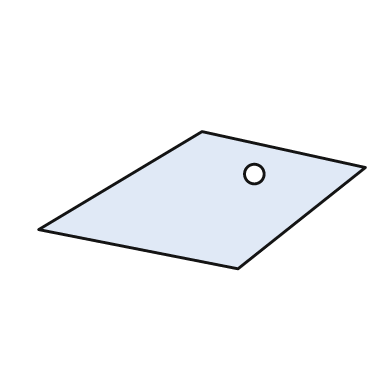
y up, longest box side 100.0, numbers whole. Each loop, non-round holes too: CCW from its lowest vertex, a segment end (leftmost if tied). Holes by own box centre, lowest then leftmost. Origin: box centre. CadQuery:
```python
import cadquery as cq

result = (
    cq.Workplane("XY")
    .moveTo(11.0, -21.0)
    .lineTo(50.0, 10.0)
    .lineTo(0.0, 21.0)
    .lineTo(-50.0, -9.0)
    .close()
    .moveTo(16.0, 8.0)
    .circle(3.0)
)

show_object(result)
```